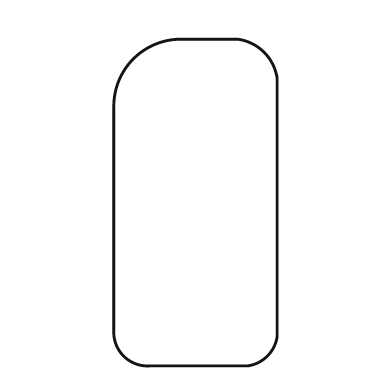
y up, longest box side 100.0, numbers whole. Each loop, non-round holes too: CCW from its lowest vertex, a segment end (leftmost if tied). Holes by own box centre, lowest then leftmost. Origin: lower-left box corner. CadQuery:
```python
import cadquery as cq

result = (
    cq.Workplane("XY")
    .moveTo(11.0, 0.0)
    .lineTo(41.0, 0.0)
    .threePointArc((47.0, 3.0), (50.0, 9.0))
    .lineTo(50.0, 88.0)
    .threePointArc((46.0, 96.0), (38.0, 100.0))
    .lineTo(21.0, 100.0)
    .threePointArc((6.0, 94.0), (0.0, 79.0))
    .lineTo(0.0, 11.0)
    .threePointArc((3.0, 3.0), (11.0, 0.0))
    .close()
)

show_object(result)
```